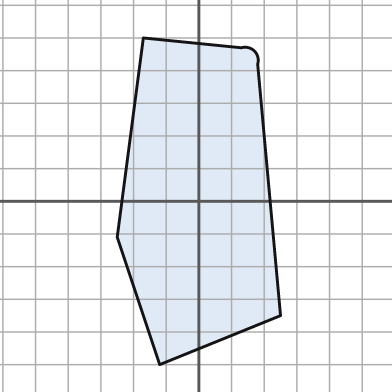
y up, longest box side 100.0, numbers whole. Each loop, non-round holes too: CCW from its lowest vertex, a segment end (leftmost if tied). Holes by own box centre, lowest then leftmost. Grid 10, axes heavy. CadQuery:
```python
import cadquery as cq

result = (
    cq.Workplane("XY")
    .moveTo(-12.0, -50.0)
    .lineTo(25.0, -35.0)
    .lineTo(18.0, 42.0)
    .threePointArc((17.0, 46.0), (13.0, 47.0))
    .lineTo(-17.0, 50.0)
    .lineTo(-25.0, -11.0)
    .close()
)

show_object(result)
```